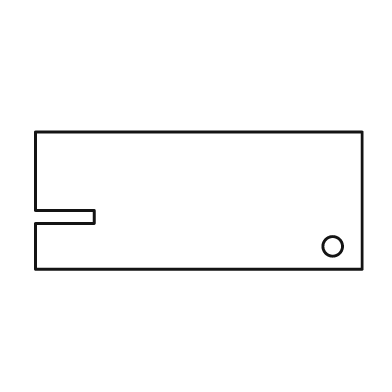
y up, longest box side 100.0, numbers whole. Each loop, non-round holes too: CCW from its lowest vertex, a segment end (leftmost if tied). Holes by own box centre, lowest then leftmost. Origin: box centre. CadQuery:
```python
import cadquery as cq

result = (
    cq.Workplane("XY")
    .moveTo(-50.0, -21.0)
    .lineTo(50.0, -21.0)
    .lineTo(50.0, 21.0)
    .lineTo(-50.0, 21.0)
    .lineTo(-50.0, -3.0)
    .lineTo(-32.0, -3.0)
    .lineTo(-32.0, -7.0)
    .lineTo(-50.0, -7.0)
    .close()
    .moveTo(41.0, -14.0)
    .circle(3.0)
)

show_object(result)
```